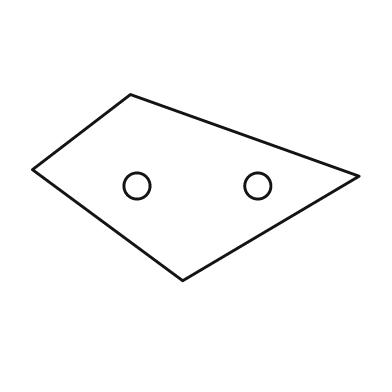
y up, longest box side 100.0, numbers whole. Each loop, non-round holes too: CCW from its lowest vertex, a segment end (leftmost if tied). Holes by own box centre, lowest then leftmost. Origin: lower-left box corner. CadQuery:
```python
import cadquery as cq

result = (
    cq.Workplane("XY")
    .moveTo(46.0, 0.0)
    .lineTo(100.0, 32.0)
    .lineTo(30.0, 57.0)
    .lineTo(0.0, 34.0)
    .close()
    .moveTo(32.0, 29.0)
    .circle(4.0)
    .moveTo(69.0, 29.0)
    .circle(4.0)
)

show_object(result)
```